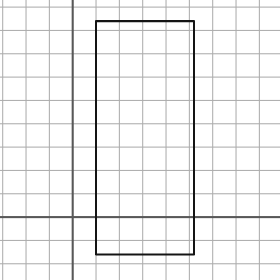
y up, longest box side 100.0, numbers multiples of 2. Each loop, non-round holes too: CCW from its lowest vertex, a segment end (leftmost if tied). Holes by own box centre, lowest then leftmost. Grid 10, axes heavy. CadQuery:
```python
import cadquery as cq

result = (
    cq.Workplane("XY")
    .moveTo(10.0, -16.0)
    .lineTo(52.0, -16.0)
    .lineTo(52.0, 84.0)
    .lineTo(10.0, 84.0)
    .close()
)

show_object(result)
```